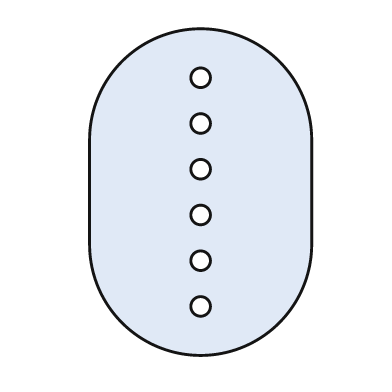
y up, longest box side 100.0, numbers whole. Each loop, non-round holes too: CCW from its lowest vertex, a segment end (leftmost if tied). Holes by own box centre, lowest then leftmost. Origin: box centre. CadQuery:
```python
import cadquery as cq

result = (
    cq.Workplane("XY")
    .moveTo(-34.0, -16.0)
    .threePointArc((0.0, -50.0), (34.0, -16.0))
    .lineTo(34.0, 16.0)
    .threePointArc((0.0, 50.0), (-34.0, 16.0))
    .close()
    .moveTo(0.0, -35.0)
    .circle(3.0)
    .moveTo(0.0, -21.0)
    .circle(3.0)
    .moveTo(0.0, -7.0)
    .circle(3.0)
    .moveTo(0.0, 7.0)
    .circle(3.0)
    .moveTo(0.0, 21.0)
    .circle(3.0)
    .moveTo(0.0, 35.0)
    .circle(3.0)
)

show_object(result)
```